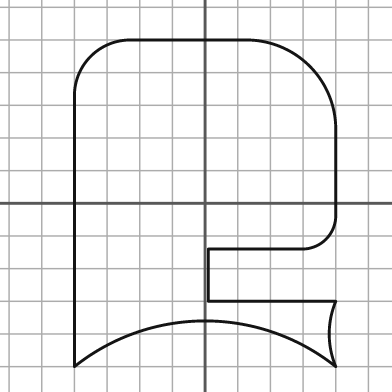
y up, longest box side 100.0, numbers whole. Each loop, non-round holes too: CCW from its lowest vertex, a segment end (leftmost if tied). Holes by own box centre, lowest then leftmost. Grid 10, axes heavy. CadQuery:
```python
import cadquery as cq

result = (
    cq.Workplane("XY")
    .moveTo(-40.0, -50.0)
    .threePointArc((0.0, -36.0), (40.0, -50.0))
    .threePointArc((38.0, -40.0), (40.0, -30.0))
    .lineTo(1.0, -30.0)
    .lineTo(1.0, -14.0)
    .lineTo(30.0, -14.0)
    .threePointArc((37.0, -11.0), (40.0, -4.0))
    .lineTo(40.0, 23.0)
    .threePointArc((32.0, 42.0), (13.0, 50.0))
    .lineTo(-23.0, 50.0)
    .threePointArc((-35.0, 45.0), (-40.0, 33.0))
    .close()
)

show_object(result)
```